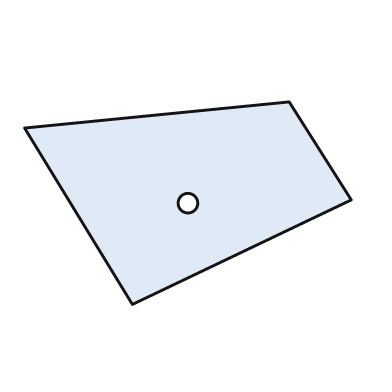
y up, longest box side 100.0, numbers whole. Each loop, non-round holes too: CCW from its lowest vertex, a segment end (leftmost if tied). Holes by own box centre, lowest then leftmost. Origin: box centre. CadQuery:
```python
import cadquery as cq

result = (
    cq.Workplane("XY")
    .moveTo(-17.0, -31.0)
    .lineTo(50.0, 1.0)
    .lineTo(31.0, 31.0)
    .lineTo(-50.0, 23.0)
    .close()
    .moveTo(0.0, 0.0)
    .circle(3.0)
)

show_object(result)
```